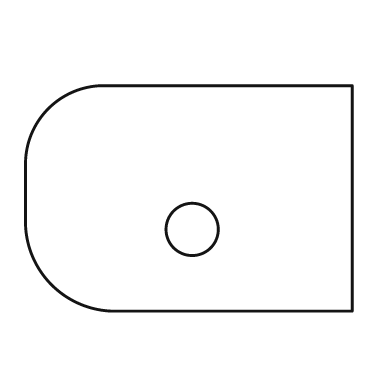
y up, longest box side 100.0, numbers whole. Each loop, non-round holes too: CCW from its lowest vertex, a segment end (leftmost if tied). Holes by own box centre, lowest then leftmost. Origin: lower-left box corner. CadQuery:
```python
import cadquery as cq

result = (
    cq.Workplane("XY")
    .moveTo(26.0, 0.0)
    .lineTo(100.0, 0.0)
    .lineTo(100.0, 69.0)
    .lineTo(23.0, 69.0)
    .threePointArc((7.0, 62.0), (0.0, 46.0))
    .lineTo(0.0, 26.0)
    .threePointArc((8.0, 8.0), (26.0, 0.0))
    .close()
    .moveTo(51.0, 25.0)
    .circle(8.0)
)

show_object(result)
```